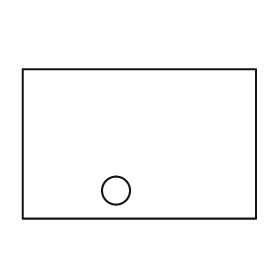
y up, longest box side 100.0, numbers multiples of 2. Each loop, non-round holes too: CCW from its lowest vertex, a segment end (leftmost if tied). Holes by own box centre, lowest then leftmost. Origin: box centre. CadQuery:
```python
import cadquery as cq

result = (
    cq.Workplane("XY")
    .moveTo(-50.0, -32.0)
    .lineTo(50.0, -32.0)
    .lineTo(50.0, 32.0)
    .lineTo(-50.0, 32.0)
    .close()
    .moveTo(-10.0, -20.0)
    .circle(6.0)
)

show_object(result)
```